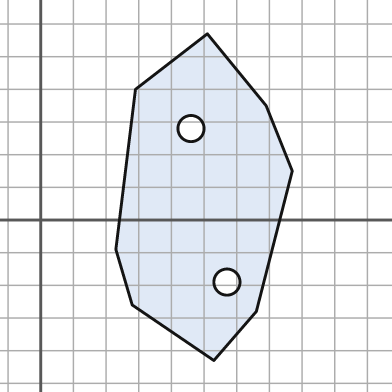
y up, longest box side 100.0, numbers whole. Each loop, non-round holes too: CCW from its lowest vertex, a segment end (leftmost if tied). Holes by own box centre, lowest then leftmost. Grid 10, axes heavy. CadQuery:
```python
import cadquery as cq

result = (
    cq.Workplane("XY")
    .moveTo(53.0, -43.0)
    .lineTo(66.0, -28.0)
    .lineTo(77.0, 15.0)
    .lineTo(69.0, 35.0)
    .lineTo(51.0, 57.0)
    .lineTo(29.0, 40.0)
    .lineTo(23.0, -9.0)
    .lineTo(28.0, -26.0)
    .close()
    .moveTo(57.0, -19.0)
    .circle(4.0)
    .moveTo(46.0, 28.0)
    .circle(4.0)
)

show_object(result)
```